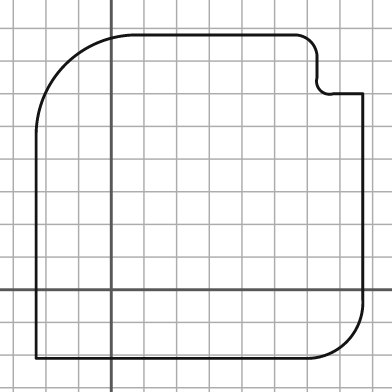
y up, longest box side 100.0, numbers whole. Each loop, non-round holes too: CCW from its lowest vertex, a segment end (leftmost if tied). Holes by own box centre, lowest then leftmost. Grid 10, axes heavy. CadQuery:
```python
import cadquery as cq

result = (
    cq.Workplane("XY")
    .moveTo(-23.0, -21.0)
    .lineTo(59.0, -21.0)
    .threePointArc((72.0, -16.0), (77.0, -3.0))
    .lineTo(77.0, 60.0)
    .lineTo(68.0, 60.0)
    .threePointArc((64.0, 61.0), (63.0, 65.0))
    .lineTo(63.0, 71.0)
    .threePointArc((61.0, 76.0), (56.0, 78.0))
    .lineTo(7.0, 78.0)
    .threePointArc((-14.0, 69.0), (-23.0, 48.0))
    .close()
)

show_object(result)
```